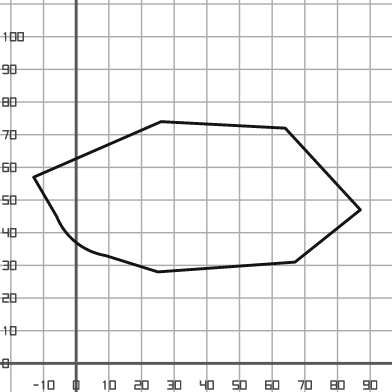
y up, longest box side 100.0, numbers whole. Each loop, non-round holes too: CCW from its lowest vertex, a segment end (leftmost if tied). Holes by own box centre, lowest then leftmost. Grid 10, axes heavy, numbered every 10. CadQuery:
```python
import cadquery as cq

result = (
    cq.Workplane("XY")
    .moveTo(25.0, 28.0)
    .lineTo(67.0, 31.0)
    .lineTo(87.0, 47.0)
    .lineTo(64.0, 72.0)
    .lineTo(26.0, 74.0)
    .lineTo(-13.0, 57.0)
    .lineTo(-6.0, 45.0)
    .threePointArc((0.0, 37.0), (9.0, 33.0))
    .close()
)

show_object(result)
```